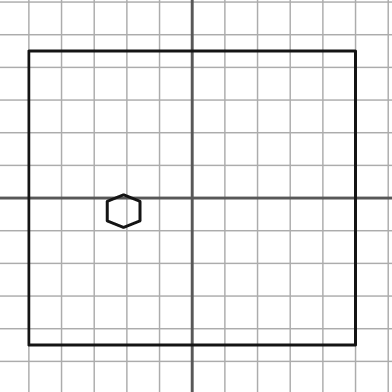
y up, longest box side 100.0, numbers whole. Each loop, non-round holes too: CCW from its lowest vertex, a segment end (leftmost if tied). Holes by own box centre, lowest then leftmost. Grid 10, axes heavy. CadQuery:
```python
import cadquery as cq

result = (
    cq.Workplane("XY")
    .moveTo(-50.0, -45.0)
    .lineTo(50.0, -45.0)
    .lineTo(50.0, 45.0)
    .lineTo(-50.0, 45.0)
    .close()
    .moveTo(-21.0, -9.0)
    .lineTo(-16.0, -7.0)
    .lineTo(-16.0, -1.0)
    .lineTo(-21.0, 1.0)
    .lineTo(-26.0, -1.0)
    .lineTo(-26.0, -7.0)
    .close()
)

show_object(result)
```